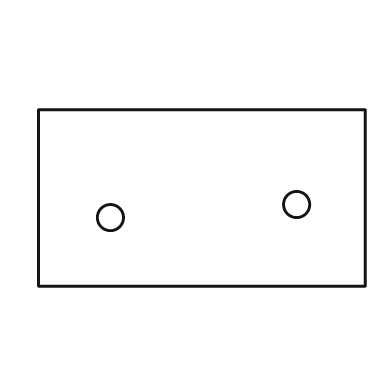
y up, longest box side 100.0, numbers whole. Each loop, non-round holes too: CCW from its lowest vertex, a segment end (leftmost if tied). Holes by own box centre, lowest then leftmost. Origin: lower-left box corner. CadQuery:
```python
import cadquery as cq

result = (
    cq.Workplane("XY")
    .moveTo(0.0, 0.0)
    .lineTo(100.0, 0.0)
    .lineTo(100.0, 54.0)
    .lineTo(0.0, 54.0)
    .close()
    .moveTo(22.0, 21.0)
    .circle(4.0)
    .moveTo(79.0, 25.0)
    .circle(4.0)
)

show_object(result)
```